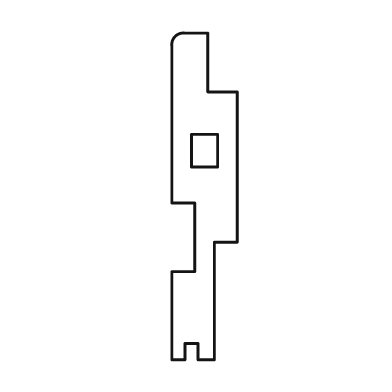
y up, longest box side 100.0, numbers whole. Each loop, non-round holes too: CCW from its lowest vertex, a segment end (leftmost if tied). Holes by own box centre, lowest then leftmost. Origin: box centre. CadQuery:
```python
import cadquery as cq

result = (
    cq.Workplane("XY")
    .moveTo(-10.0, -50.0)
    .lineTo(-6.0, -50.0)
    .lineTo(-6.0, -45.0)
    .lineTo(-2.0, -45.0)
    .lineTo(-2.0, -50.0)
    .lineTo(3.0, -50.0)
    .lineTo(3.0, -14.0)
    .lineTo(10.0, -14.0)
    .lineTo(10.0, 32.0)
    .lineTo(1.0, 32.0)
    .lineTo(1.0, 50.0)
    .lineTo(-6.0, 50.0)
    .threePointArc((-9.0, 49.0), (-10.0, 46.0))
    .lineTo(-10.0, -2.0)
    .lineTo(-3.0, -2.0)
    .lineTo(-3.0, -23.0)
    .lineTo(-10.0, -23.0)
    .close()
    .moveTo(-4.0, 9.0)
    .lineTo(4.0, 9.0)
    .lineTo(4.0, 19.0)
    .lineTo(-4.0, 19.0)
    .close()
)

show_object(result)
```